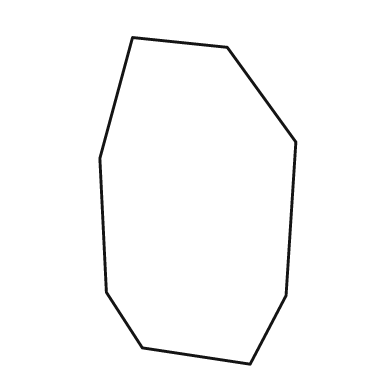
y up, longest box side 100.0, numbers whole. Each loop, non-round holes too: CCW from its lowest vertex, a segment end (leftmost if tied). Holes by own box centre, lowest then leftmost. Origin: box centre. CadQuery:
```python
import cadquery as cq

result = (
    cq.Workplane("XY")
    .moveTo(16.0, -50.0)
    .lineTo(27.0, -29.0)
    .lineTo(30.0, 18.0)
    .lineTo(9.0, 47.0)
    .lineTo(-20.0, 50.0)
    .lineTo(-30.0, 13.0)
    .lineTo(-28.0, -28.0)
    .lineTo(-17.0, -45.0)
    .close()
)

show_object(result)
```